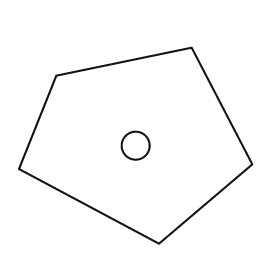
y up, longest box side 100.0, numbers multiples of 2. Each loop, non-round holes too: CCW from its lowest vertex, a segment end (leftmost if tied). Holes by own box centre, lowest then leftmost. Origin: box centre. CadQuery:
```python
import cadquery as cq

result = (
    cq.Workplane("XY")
    .moveTo(10.0, -42.0)
    .lineTo(50.0, -8.0)
    .lineTo(24.0, 42.0)
    .lineTo(-34.0, 30.0)
    .lineTo(-50.0, -10.0)
    .close()
    .moveTo(0.0, 0.0)
    .circle(6.0)
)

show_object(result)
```